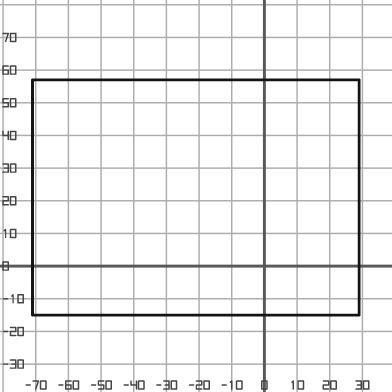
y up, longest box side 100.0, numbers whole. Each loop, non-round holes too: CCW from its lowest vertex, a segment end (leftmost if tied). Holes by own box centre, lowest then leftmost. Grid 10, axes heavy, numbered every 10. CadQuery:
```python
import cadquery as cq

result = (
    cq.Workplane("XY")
    .moveTo(-71.0, -15.0)
    .lineTo(29.0, -15.0)
    .lineTo(29.0, 57.0)
    .lineTo(-71.0, 57.0)
    .close()
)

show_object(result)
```